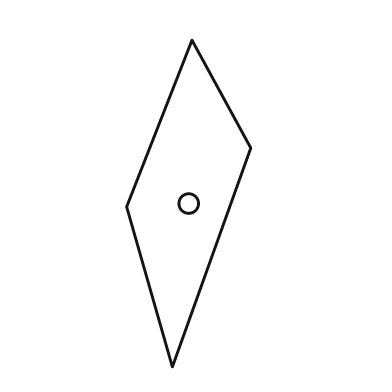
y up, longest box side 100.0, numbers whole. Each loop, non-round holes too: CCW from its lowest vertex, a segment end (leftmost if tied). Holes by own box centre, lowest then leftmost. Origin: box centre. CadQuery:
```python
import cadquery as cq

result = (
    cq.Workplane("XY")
    .moveTo(-5.0, -50.0)
    .lineTo(19.0, 17.0)
    .lineTo(1.0, 50.0)
    .lineTo(-19.0, -1.0)
    .close()
    .moveTo(0.0, 0.0)
    .circle(3.0)
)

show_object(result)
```